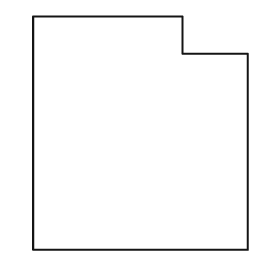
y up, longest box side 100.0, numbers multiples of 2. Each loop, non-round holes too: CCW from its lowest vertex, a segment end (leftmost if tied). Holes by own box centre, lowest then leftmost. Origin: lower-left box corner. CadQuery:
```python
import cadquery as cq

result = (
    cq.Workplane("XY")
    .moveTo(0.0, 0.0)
    .lineTo(92.0, 0.0)
    .lineTo(92.0, 84.0)
    .lineTo(64.0, 84.0)
    .lineTo(64.0, 100.0)
    .lineTo(0.0, 100.0)
    .close()
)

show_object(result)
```